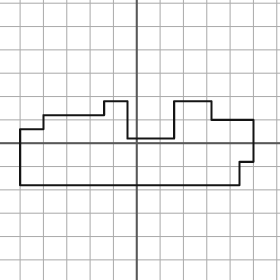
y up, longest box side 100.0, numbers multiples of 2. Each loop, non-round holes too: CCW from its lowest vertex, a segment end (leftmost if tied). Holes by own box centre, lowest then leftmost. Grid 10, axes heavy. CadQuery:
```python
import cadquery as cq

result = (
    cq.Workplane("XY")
    .moveTo(-50.0, -18.0)
    .lineTo(44.0, -18.0)
    .lineTo(44.0, -8.0)
    .lineTo(50.0, -8.0)
    .lineTo(50.0, 10.0)
    .lineTo(32.0, 10.0)
    .lineTo(32.0, 18.0)
    .lineTo(16.0, 18.0)
    .lineTo(16.0, 2.0)
    .lineTo(-4.0, 2.0)
    .lineTo(-4.0, 18.0)
    .lineTo(-14.0, 18.0)
    .lineTo(-14.0, 12.0)
    .lineTo(-40.0, 12.0)
    .lineTo(-40.0, 6.0)
    .lineTo(-50.0, 6.0)
    .close()
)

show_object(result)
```